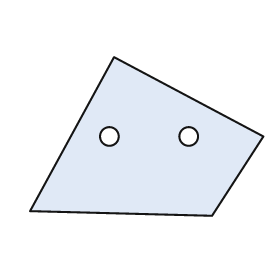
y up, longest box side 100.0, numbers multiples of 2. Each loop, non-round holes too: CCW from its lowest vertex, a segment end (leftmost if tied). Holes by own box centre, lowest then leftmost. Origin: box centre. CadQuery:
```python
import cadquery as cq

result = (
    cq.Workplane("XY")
    .moveTo(28.0, -34.0)
    .lineTo(50.0, 0.0)
    .lineTo(-14.0, 34.0)
    .lineTo(-50.0, -32.0)
    .close()
    .moveTo(-16.0, 0.0)
    .circle(4.0)
    .moveTo(18.0, 0.0)
    .circle(4.0)
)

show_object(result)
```